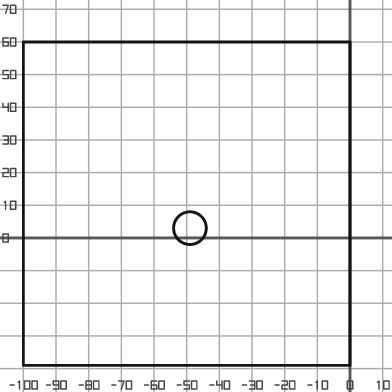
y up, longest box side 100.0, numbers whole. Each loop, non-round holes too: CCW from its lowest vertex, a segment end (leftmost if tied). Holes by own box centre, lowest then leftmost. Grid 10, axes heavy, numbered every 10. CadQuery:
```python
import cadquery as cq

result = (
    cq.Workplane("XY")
    .moveTo(-100.0, -39.0)
    .lineTo(0.0, -39.0)
    .lineTo(0.0, 60.0)
    .lineTo(-100.0, 60.0)
    .close()
    .moveTo(-49.0, 3.0)
    .circle(5.0)
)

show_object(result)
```